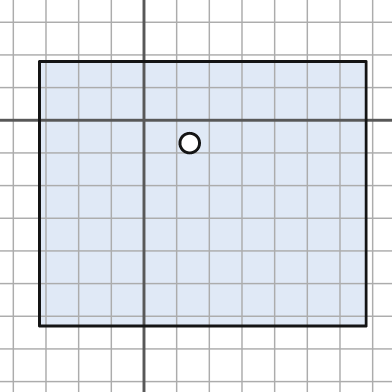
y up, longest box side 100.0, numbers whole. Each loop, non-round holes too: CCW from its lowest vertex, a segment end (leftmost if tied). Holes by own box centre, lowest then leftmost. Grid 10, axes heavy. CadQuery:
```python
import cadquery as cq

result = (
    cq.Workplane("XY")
    .moveTo(-32.0, -63.0)
    .lineTo(68.0, -63.0)
    .lineTo(68.0, 18.0)
    .lineTo(-32.0, 18.0)
    .close()
    .moveTo(14.0, -7.0)
    .circle(3.0)
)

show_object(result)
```